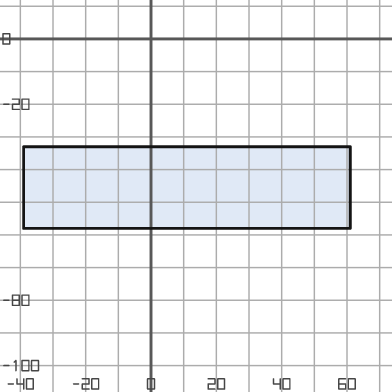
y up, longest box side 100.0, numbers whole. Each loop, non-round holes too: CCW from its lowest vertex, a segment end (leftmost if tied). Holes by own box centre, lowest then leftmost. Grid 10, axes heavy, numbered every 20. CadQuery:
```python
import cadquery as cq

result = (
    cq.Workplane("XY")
    .moveTo(-39.0, -58.0)
    .lineTo(61.0, -58.0)
    .lineTo(61.0, -33.0)
    .lineTo(-39.0, -33.0)
    .close()
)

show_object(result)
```